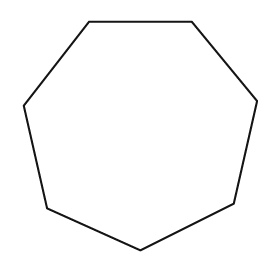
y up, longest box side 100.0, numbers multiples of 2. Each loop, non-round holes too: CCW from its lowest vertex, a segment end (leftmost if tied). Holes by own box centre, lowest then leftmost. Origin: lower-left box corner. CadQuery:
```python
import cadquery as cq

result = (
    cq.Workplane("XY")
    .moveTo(50.0, 0.0)
    .lineTo(90.0, 20.0)
    .lineTo(100.0, 64.0)
    .lineTo(72.0, 98.0)
    .lineTo(28.0, 98.0)
    .lineTo(0.0, 62.0)
    .lineTo(10.0, 18.0)
    .close()
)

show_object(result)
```